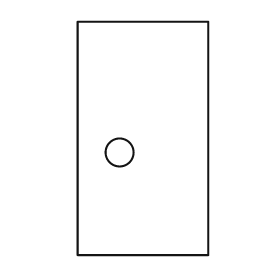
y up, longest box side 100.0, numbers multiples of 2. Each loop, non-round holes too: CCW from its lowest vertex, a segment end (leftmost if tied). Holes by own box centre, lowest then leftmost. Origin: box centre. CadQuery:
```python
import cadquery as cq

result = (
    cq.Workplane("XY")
    .moveTo(-28.0, -50.0)
    .lineTo(28.0, -50.0)
    .lineTo(28.0, 50.0)
    .lineTo(-28.0, 50.0)
    .close()
    .moveTo(-10.0, -6.0)
    .circle(6.0)
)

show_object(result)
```